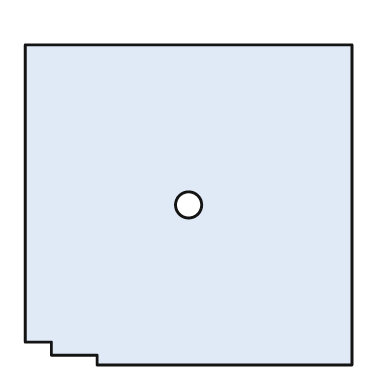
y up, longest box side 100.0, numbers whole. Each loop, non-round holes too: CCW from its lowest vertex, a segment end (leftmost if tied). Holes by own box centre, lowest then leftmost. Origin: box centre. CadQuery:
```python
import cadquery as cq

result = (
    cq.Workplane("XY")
    .moveTo(-28.0, -49.0)
    .lineTo(50.0, -49.0)
    .lineTo(50.0, 49.0)
    .lineTo(-50.0, 49.0)
    .lineTo(-50.0, -42.0)
    .lineTo(-42.0, -42.0)
    .lineTo(-42.0, -46.0)
    .lineTo(-28.0, -46.0)
    .close()
    .moveTo(0.0, 0.0)
    .circle(4.0)
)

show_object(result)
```